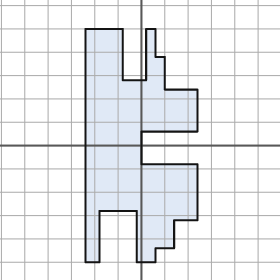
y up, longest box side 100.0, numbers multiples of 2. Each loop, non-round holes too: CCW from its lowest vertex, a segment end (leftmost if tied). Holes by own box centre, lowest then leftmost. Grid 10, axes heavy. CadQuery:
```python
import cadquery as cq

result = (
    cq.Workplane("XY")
    .moveTo(-24.0, -50.0)
    .lineTo(-18.0, -50.0)
    .lineTo(-18.0, -28.0)
    .lineTo(-2.0, -28.0)
    .lineTo(-2.0, -50.0)
    .lineTo(6.0, -50.0)
    .lineTo(6.0, -44.0)
    .lineTo(14.0, -44.0)
    .lineTo(14.0, -32.0)
    .lineTo(24.0, -32.0)
    .lineTo(24.0, -8.0)
    .lineTo(0.0, -8.0)
    .lineTo(0.0, 6.0)
    .lineTo(24.0, 6.0)
    .lineTo(24.0, 24.0)
    .lineTo(10.0, 24.0)
    .lineTo(10.0, 38.0)
    .lineTo(6.0, 38.0)
    .lineTo(6.0, 50.0)
    .lineTo(2.0, 50.0)
    .lineTo(2.0, 28.0)
    .lineTo(-8.0, 28.0)
    .lineTo(-8.0, 50.0)
    .lineTo(-24.0, 50.0)
    .close()
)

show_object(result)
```